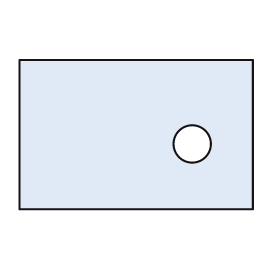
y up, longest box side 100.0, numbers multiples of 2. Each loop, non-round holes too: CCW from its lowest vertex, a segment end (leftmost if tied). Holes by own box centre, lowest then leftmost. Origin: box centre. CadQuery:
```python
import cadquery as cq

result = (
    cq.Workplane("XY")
    .moveTo(-50.0, -32.0)
    .lineTo(50.0, -32.0)
    .lineTo(50.0, 32.0)
    .lineTo(-50.0, 32.0)
    .close()
    .moveTo(24.0, -4.0)
    .circle(8.0)
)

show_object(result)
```